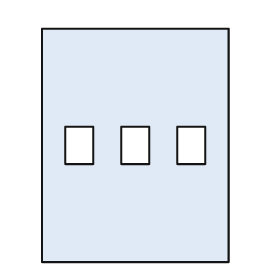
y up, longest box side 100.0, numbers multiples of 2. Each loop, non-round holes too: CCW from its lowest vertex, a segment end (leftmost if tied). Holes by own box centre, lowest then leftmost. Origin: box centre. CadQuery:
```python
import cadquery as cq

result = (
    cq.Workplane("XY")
    .moveTo(-40.0, -50.0)
    .lineTo(40.0, -50.0)
    .lineTo(40.0, 50.0)
    .lineTo(-40.0, 50.0)
    .close()
    .moveTo(-30.0, -8.0)
    .lineTo(-18.0, -8.0)
    .lineTo(-18.0, 8.0)
    .lineTo(-30.0, 8.0)
    .close()
    .moveTo(-6.0, -8.0)
    .lineTo(6.0, -8.0)
    .lineTo(6.0, 8.0)
    .lineTo(-6.0, 8.0)
    .close()
    .moveTo(18.0, -8.0)
    .lineTo(30.0, -8.0)
    .lineTo(30.0, 8.0)
    .lineTo(18.0, 8.0)
    .close()
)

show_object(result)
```